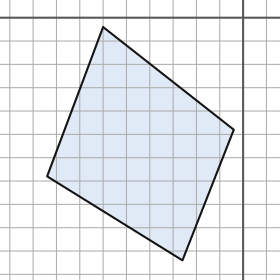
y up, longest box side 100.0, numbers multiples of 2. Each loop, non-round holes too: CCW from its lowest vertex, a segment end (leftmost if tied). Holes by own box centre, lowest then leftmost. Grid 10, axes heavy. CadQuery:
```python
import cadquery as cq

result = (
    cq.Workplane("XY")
    .moveTo(-26.0, -104.0)
    .lineTo(-4.0, -48.0)
    .lineTo(-60.0, -4.0)
    .lineTo(-84.0, -68.0)
    .close()
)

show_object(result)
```